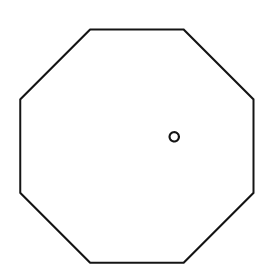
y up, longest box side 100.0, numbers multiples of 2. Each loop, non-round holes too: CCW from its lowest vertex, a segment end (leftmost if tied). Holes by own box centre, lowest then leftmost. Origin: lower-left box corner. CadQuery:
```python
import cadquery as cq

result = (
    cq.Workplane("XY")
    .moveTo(30.0, 0.0)
    .lineTo(70.0, 0.0)
    .lineTo(100.0, 30.0)
    .lineTo(100.0, 70.0)
    .lineTo(70.0, 100.0)
    .lineTo(30.0, 100.0)
    .lineTo(0.0, 70.0)
    .lineTo(0.0, 30.0)
    .close()
    .moveTo(66.0, 54.0)
    .circle(2.0)
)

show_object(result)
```